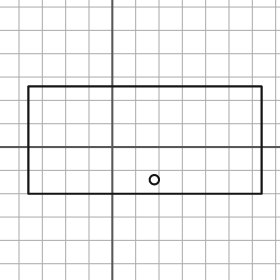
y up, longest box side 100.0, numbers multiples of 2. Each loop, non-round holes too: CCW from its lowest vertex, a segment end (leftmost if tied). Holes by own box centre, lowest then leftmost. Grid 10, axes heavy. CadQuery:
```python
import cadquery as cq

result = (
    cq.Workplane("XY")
    .moveTo(-36.0, -20.0)
    .lineTo(64.0, -20.0)
    .lineTo(64.0, 26.0)
    .lineTo(-36.0, 26.0)
    .close()
    .moveTo(18.0, -14.0)
    .circle(2.0)
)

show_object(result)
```